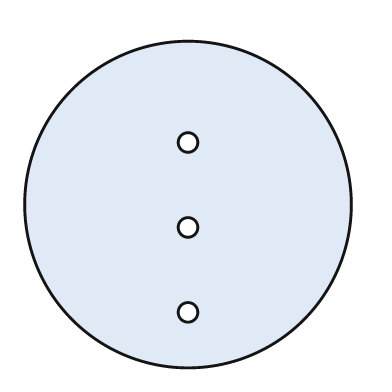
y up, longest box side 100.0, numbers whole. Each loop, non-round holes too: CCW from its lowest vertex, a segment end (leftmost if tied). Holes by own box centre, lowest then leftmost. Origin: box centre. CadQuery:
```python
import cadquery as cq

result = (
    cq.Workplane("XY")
    .moveTo(0.0, 0.0)
    .circle(50.0)
    .moveTo(0.0, -33.0)
    .circle(3.0)
    .moveTo(0.0, -7.0)
    .circle(3.0)
    .moveTo(0.0, 19.0)
    .circle(3.0)
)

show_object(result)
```